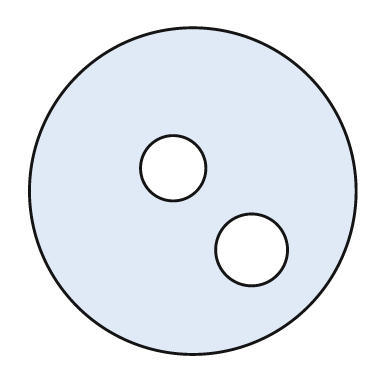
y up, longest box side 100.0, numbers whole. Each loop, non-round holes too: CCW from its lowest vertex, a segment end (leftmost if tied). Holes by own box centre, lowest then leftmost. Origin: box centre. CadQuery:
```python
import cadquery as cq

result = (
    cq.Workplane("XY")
    .moveTo(0.0, 0.0)
    .circle(50.0)
    .moveTo(18.0, -18.0)
    .circle(11.0)
    .moveTo(-6.0, 7.0)
    .circle(10.0)
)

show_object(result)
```